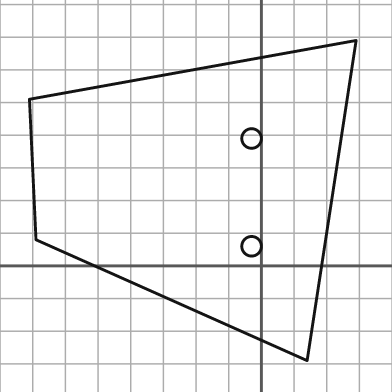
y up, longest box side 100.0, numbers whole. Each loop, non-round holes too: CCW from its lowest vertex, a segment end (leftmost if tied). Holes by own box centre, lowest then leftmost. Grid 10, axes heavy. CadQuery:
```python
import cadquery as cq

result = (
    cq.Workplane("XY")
    .moveTo(14.0, -29.0)
    .lineTo(29.0, 69.0)
    .lineTo(-71.0, 51.0)
    .lineTo(-69.0, 8.0)
    .close()
    .moveTo(-3.0, 6.0)
    .circle(3.0)
    .moveTo(-3.0, 39.0)
    .circle(3.0)
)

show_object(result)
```